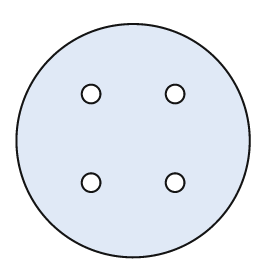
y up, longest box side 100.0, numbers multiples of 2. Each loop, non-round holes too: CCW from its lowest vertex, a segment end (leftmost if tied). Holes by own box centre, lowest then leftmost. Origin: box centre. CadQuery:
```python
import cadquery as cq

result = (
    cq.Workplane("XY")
    .moveTo(0.0, 0.0)
    .circle(50.0)
    .moveTo(-18.0, -18.0)
    .circle(4.0)
    .moveTo(18.0, -18.0)
    .circle(4.0)
    .moveTo(-18.0, 20.0)
    .circle(4.0)
    .moveTo(18.0, 20.0)
    .circle(4.0)
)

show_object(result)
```